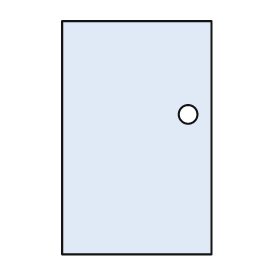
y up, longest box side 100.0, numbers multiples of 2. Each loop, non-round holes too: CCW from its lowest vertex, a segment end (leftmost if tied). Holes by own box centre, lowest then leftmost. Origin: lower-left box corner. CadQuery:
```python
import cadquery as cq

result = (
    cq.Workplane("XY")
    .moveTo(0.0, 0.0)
    .lineTo(64.0, 0.0)
    .lineTo(64.0, 100.0)
    .lineTo(0.0, 100.0)
    .close()
    .moveTo(54.0, 60.0)
    .circle(4.0)
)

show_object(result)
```